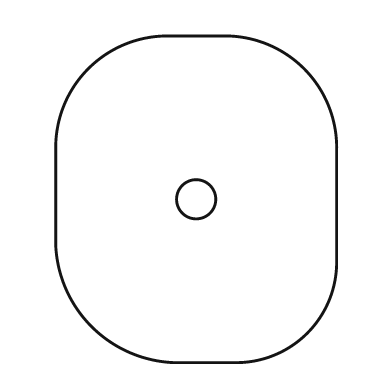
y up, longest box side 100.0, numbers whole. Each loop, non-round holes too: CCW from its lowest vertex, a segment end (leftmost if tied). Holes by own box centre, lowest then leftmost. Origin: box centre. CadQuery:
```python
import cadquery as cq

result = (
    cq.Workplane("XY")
    .moveTo(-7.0, -50.0)
    .lineTo(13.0, -50.0)
    .threePointArc((34.0, -41.0), (43.0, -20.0))
    .lineTo(43.0, 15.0)
    .threePointArc((33.0, 40.0), (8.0, 50.0))
    .lineTo(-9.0, 50.0)
    .threePointArc((-33.0, 40.0), (-43.0, 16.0))
    .lineTo(-43.0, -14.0)
    .threePointArc((-32.0, -39.0), (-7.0, -50.0))
    .close()
    .moveTo(0.0, 0.0)
    .circle(6.0)
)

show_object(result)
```